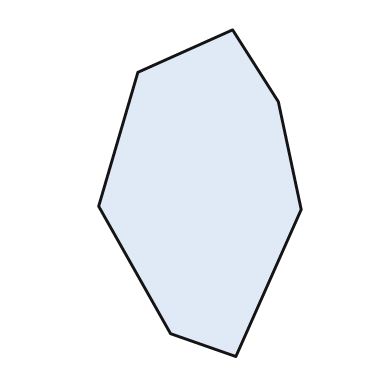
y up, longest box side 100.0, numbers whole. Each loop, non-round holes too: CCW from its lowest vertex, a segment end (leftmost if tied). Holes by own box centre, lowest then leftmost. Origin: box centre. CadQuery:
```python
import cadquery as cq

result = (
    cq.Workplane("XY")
    .moveTo(11.0, -50.0)
    .lineTo(31.0, -5.0)
    .lineTo(24.0, 28.0)
    .lineTo(10.0, 50.0)
    .lineTo(-19.0, 37.0)
    .lineTo(-31.0, -4.0)
    .lineTo(-9.0, -43.0)
    .close()
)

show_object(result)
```